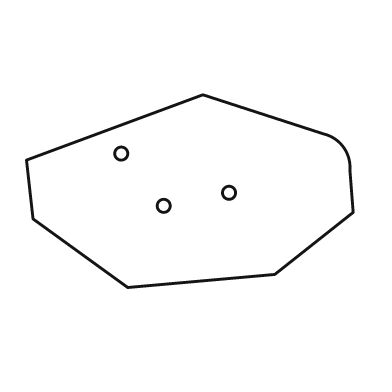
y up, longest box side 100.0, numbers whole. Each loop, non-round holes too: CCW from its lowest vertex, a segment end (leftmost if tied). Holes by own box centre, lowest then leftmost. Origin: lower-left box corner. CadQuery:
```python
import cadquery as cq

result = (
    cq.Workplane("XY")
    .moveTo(31.0, 0.0)
    .lineTo(76.0, 4.0)
    .lineTo(100.0, 23.0)
    .lineTo(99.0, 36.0)
    .threePointArc((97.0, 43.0), (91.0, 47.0))
    .lineTo(54.0, 59.0)
    .lineTo(0.0, 39.0)
    .lineTo(2.0, 21.0)
    .close()
    .moveTo(42.0, 25.0)
    .circle(2.0)
    .moveTo(62.0, 29.0)
    .circle(2.0)
    .moveTo(29.0, 41.0)
    .circle(2.0)
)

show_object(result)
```